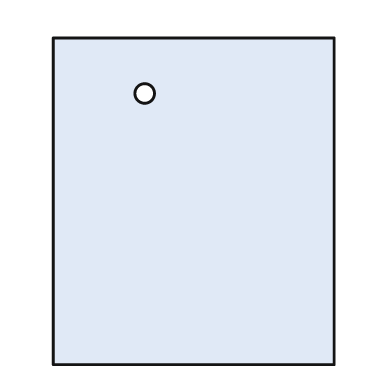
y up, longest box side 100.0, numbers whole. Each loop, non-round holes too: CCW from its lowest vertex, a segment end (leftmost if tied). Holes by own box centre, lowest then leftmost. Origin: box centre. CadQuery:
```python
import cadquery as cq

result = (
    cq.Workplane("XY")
    .moveTo(-43.0, -50.0)
    .lineTo(43.0, -50.0)
    .lineTo(43.0, 50.0)
    .lineTo(-43.0, 50.0)
    .close()
    .moveTo(-15.0, 33.0)
    .circle(3.0)
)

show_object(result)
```